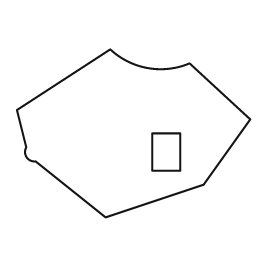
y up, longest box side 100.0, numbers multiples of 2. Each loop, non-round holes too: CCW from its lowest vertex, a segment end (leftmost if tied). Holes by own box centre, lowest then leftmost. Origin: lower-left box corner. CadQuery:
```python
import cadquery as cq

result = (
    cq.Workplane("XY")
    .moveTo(38.0, 0.0)
    .lineTo(80.0, 14.0)
    .lineTo(100.0, 42.0)
    .lineTo(74.0, 66.0)
    .threePointArc((56.0, 64.0), (40.0, 72.0))
    .lineTo(0.0, 46.0)
    .lineTo(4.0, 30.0)
    .threePointArc((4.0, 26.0), (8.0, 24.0))
    .close()
    .moveTo(58.0, 20.0)
    .lineTo(70.0, 20.0)
    .lineTo(70.0, 36.0)
    .lineTo(58.0, 36.0)
    .close()
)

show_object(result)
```